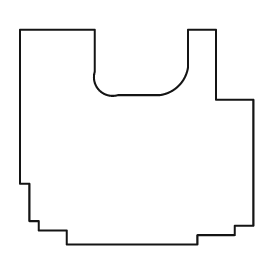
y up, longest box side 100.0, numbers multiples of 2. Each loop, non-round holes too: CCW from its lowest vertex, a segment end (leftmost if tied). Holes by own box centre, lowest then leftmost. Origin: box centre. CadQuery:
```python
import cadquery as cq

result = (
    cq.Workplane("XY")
    .moveTo(-30.0, -46.0)
    .lineTo(26.0, -46.0)
    .lineTo(26.0, -42.0)
    .lineTo(42.0, -42.0)
    .lineTo(42.0, -38.0)
    .lineTo(50.0, -38.0)
    .lineTo(50.0, 16.0)
    .lineTo(34.0, 16.0)
    .lineTo(34.0, 46.0)
    .lineTo(22.0, 46.0)
    .lineTo(22.0, 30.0)
    .threePointArc((18.0, 22.0), (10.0, 18.0))
    .lineTo(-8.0, 18.0)
    .threePointArc((-16.0, 20.0), (-18.0, 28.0))
    .lineTo(-18.0, 46.0)
    .lineTo(-50.0, 46.0)
    .lineTo(-50.0, -20.0)
    .lineTo(-46.0, -20.0)
    .lineTo(-46.0, -36.0)
    .lineTo(-42.0, -36.0)
    .lineTo(-42.0, -40.0)
    .lineTo(-30.0, -40.0)
    .close()
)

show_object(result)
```